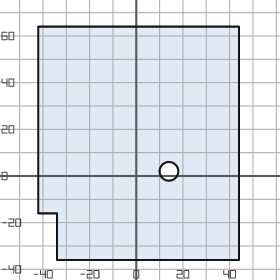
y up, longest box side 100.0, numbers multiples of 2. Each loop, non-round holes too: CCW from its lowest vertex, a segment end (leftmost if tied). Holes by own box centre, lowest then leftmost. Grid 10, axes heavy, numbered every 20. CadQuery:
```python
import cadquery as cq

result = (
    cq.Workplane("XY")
    .moveTo(-34.0, -36.0)
    .lineTo(44.0, -36.0)
    .lineTo(44.0, 64.0)
    .lineTo(-42.0, 64.0)
    .lineTo(-42.0, -16.0)
    .lineTo(-34.0, -16.0)
    .close()
    .moveTo(14.0, 2.0)
    .circle(4.0)
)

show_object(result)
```